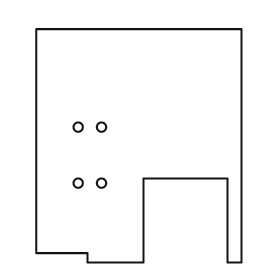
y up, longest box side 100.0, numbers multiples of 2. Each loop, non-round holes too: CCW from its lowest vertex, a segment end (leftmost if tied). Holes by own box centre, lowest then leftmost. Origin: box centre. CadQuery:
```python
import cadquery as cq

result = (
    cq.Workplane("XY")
    .moveTo(-22.0, -50.0)
    .lineTo(2.0, -50.0)
    .lineTo(2.0, -14.0)
    .lineTo(38.0, -14.0)
    .lineTo(38.0, -50.0)
    .lineTo(44.0, -50.0)
    .lineTo(44.0, 50.0)
    .lineTo(-44.0, 50.0)
    .lineTo(-44.0, -46.0)
    .lineTo(-22.0, -46.0)
    .close()
    .moveTo(-26.0, -16.0)
    .circle(2.0)
    .moveTo(-16.0, -16.0)
    .circle(2.0)
    .moveTo(-26.0, 8.0)
    .circle(2.0)
    .moveTo(-16.0, 8.0)
    .circle(2.0)
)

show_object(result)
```